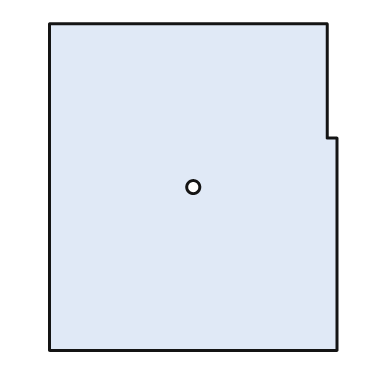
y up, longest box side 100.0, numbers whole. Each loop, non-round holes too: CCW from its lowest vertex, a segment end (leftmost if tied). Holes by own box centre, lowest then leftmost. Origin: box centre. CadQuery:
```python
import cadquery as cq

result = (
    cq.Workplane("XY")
    .moveTo(-44.0, -50.0)
    .lineTo(44.0, -50.0)
    .lineTo(44.0, 15.0)
    .lineTo(41.0, 15.0)
    .lineTo(41.0, 50.0)
    .lineTo(-44.0, 50.0)
    .close()
    .moveTo(0.0, 0.0)
    .circle(2.0)
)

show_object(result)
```